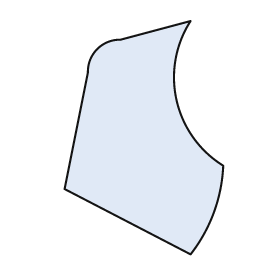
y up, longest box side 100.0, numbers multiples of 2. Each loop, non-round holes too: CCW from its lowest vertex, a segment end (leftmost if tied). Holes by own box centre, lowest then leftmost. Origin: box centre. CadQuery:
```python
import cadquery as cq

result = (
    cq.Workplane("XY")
    .moveTo(20.0, -50.0)
    .threePointArc((30.0, -32.0), (34.0, -12.0))
    .threePointArc((14.0, 16.0), (20.0, 50.0))
    .lineTo(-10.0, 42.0)
    .threePointArc((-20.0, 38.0), (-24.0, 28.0))
    .lineTo(-34.0, -22.0)
    .close()
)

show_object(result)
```